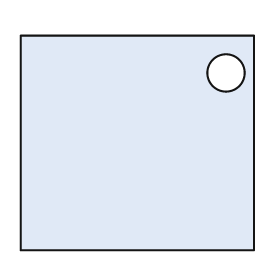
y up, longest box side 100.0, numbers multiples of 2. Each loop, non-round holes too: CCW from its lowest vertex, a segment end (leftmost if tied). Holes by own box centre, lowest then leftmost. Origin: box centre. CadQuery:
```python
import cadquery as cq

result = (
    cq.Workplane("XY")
    .moveTo(-50.0, -46.0)
    .lineTo(50.0, -46.0)
    .lineTo(50.0, 46.0)
    .lineTo(-50.0, 46.0)
    .close()
    .moveTo(38.0, 30.0)
    .circle(8.0)
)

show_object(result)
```